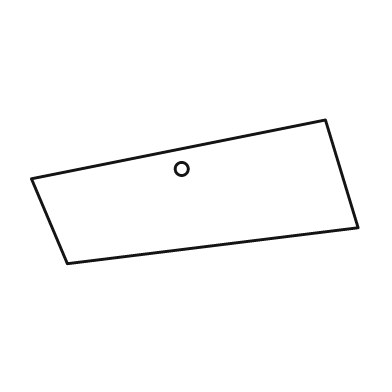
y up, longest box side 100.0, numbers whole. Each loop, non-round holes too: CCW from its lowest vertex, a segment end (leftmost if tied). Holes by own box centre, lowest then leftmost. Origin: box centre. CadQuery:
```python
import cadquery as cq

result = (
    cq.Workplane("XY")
    .moveTo(-39.0, -22.0)
    .lineTo(50.0, -11.0)
    .lineTo(40.0, 22.0)
    .lineTo(-50.0, 4.0)
    .close()
    .moveTo(-4.0, 7.0)
    .circle(2.0)
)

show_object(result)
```